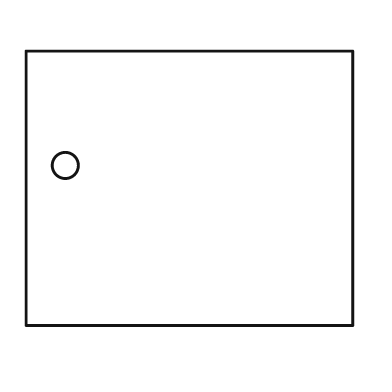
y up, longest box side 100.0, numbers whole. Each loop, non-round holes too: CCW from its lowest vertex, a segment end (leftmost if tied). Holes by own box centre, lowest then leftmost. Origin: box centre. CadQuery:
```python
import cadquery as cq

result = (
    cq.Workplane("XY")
    .moveTo(-50.0, -42.0)
    .lineTo(50.0, -42.0)
    .lineTo(50.0, 42.0)
    .lineTo(-50.0, 42.0)
    .close()
    .moveTo(-38.0, 7.0)
    .circle(4.0)
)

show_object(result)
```